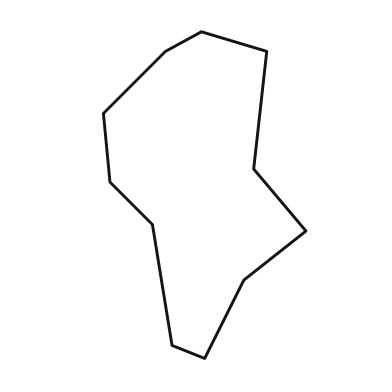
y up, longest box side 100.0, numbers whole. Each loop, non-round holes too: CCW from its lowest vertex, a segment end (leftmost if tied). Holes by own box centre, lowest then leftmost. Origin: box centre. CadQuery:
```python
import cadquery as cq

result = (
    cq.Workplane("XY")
    .moveTo(0.0, -50.0)
    .lineTo(12.0, -26.0)
    .lineTo(31.0, -11.0)
    .lineTo(15.0, 8.0)
    .lineTo(19.0, 44.0)
    .lineTo(-1.0, 50.0)
    .lineTo(-12.0, 44.0)
    .lineTo(-31.0, 25.0)
    .lineTo(-29.0, 4.0)
    .lineTo(-16.0, -9.0)
    .lineTo(-10.0, -46.0)
    .close()
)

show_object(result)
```